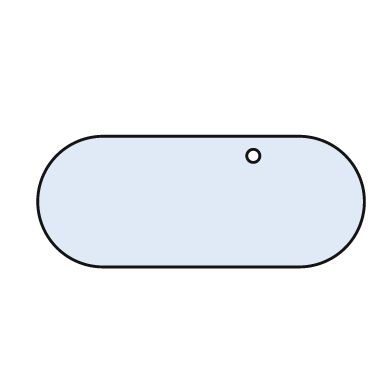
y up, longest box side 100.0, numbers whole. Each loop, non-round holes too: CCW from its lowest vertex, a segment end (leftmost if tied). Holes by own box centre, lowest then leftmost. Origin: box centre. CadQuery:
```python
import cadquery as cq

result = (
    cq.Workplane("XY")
    .moveTo(-30.0, -20.0)
    .lineTo(30.0, -20.0)
    .threePointArc((50.0, 0.0), (30.0, 20.0))
    .lineTo(-30.0, 20.0)
    .threePointArc((-50.0, 0.0), (-30.0, -20.0))
    .close()
    .moveTo(16.0, 14.0)
    .circle(2.0)
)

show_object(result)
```